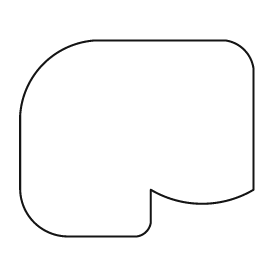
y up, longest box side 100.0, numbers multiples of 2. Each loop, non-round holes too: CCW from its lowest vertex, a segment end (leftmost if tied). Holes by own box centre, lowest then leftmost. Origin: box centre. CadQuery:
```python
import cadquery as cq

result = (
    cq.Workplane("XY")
    .moveTo(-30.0, -42.0)
    .lineTo(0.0, -42.0)
    .threePointArc((4.0, -40.0), (6.0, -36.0))
    .lineTo(6.0, -22.0)
    .threePointArc((28.0, -28.0), (50.0, -22.0))
    .lineTo(50.0, 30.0)
    .threePointArc((46.0, 38.0), (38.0, 42.0))
    .lineTo(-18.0, 42.0)
    .threePointArc((-40.0, 32.0), (-50.0, 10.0))
    .lineTo(-50.0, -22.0)
    .threePointArc((-44.0, -36.0), (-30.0, -42.0))
    .close()
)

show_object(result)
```